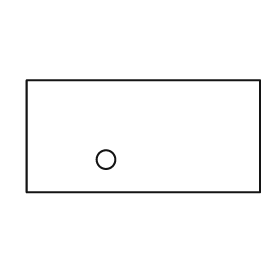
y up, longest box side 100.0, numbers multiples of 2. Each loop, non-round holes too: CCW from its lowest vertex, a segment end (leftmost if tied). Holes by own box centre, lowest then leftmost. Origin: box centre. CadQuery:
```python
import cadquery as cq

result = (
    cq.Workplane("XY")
    .moveTo(-50.0, -24.0)
    .lineTo(50.0, -24.0)
    .lineTo(50.0, 24.0)
    .lineTo(-50.0, 24.0)
    .close()
    .moveTo(-16.0, -10.0)
    .circle(4.0)
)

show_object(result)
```